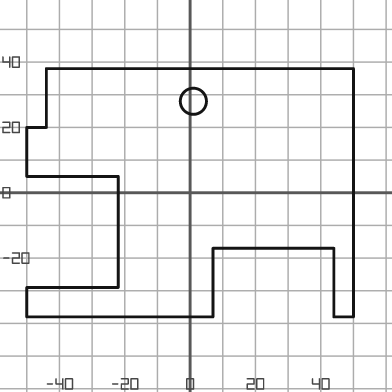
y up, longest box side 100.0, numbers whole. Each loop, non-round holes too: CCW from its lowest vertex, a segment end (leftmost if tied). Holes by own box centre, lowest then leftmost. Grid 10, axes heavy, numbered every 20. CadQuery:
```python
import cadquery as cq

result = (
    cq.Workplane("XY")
    .moveTo(-50.0, -38.0)
    .lineTo(7.0, -38.0)
    .lineTo(7.0, -17.0)
    .lineTo(44.0, -17.0)
    .lineTo(44.0, -38.0)
    .lineTo(50.0, -38.0)
    .lineTo(50.0, 38.0)
    .lineTo(-44.0, 38.0)
    .lineTo(-44.0, 20.0)
    .lineTo(-50.0, 20.0)
    .lineTo(-50.0, 5.0)
    .lineTo(-22.0, 5.0)
    .lineTo(-22.0, -29.0)
    .lineTo(-50.0, -29.0)
    .close()
    .moveTo(1.0, 28.0)
    .circle(4.0)
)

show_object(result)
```